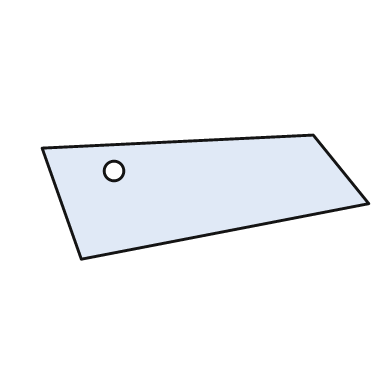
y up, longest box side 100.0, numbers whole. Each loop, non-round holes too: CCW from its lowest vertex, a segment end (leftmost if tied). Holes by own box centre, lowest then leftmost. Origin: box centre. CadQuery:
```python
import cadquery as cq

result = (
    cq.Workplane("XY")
    .moveTo(-38.0, -19.0)
    .lineTo(50.0, -2.0)
    .lineTo(33.0, 19.0)
    .lineTo(-50.0, 15.0)
    .close()
    .moveTo(-28.0, 8.0)
    .circle(3.0)
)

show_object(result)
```